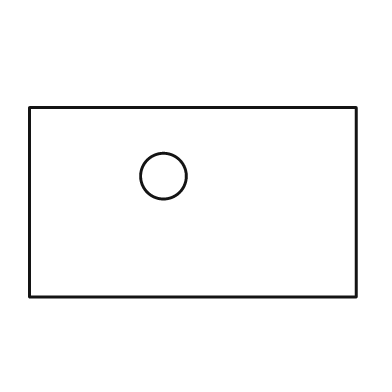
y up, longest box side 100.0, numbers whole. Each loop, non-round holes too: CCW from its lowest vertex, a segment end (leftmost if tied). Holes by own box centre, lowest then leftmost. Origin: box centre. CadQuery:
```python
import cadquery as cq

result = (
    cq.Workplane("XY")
    .moveTo(-50.0, -29.0)
    .lineTo(50.0, -29.0)
    .lineTo(50.0, 29.0)
    .lineTo(-50.0, 29.0)
    .close()
    .moveTo(-9.0, 8.0)
    .circle(7.0)
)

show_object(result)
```